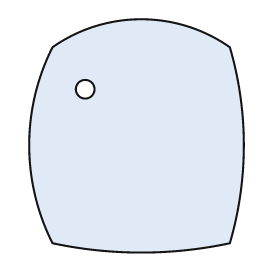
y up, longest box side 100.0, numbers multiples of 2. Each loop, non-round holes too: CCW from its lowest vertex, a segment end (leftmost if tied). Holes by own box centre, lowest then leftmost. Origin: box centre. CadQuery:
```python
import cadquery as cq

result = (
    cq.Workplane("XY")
    .moveTo(-36.0, -46.0)
    .threePointArc((2.0, -50.0), (40.0, -46.0))
    .threePointArc((46.0, -4.0), (40.0, 38.0))
    .threePointArc((2.0, 50.0), (-36.0, 38.0))
    .threePointArc((-46.0, -4.0), (-36.0, -46.0))
    .close()
    .moveTo(-22.0, 20.0)
    .circle(4.0)
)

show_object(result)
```